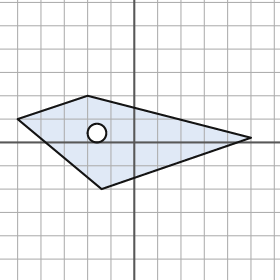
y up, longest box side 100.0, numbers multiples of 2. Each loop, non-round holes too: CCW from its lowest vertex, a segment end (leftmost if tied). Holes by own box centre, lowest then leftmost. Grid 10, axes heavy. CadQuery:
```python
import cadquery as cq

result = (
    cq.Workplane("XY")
    .moveTo(-14.0, -20.0)
    .lineTo(50.0, 2.0)
    .lineTo(-20.0, 20.0)
    .lineTo(-50.0, 10.0)
    .close()
    .moveTo(-16.0, 4.0)
    .circle(4.0)
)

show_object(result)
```